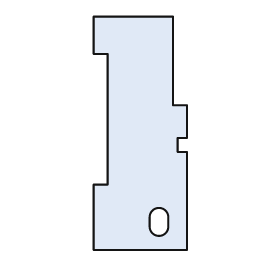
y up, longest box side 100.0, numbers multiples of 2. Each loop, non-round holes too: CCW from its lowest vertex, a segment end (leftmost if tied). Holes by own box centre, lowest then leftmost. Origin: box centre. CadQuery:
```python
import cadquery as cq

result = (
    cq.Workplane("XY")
    .moveTo(-20.0, -50.0)
    .lineTo(20.0, -50.0)
    .lineTo(20.0, -8.0)
    .lineTo(16.0, -8.0)
    .lineTo(16.0, -2.0)
    .lineTo(20.0, -2.0)
    .lineTo(20.0, 12.0)
    .lineTo(14.0, 12.0)
    .lineTo(14.0, 50.0)
    .lineTo(-20.0, 50.0)
    .lineTo(-20.0, 34.0)
    .lineTo(-14.0, 34.0)
    .lineTo(-14.0, -22.0)
    .lineTo(-20.0, -22.0)
    .close()
    .moveTo(4.0, -40.0)
    .threePointArc((8.0, -44.0), (12.0, -40.0))
    .lineTo(12.0, -36.0)
    .threePointArc((8.0, -32.0), (4.0, -36.0))
    .close()
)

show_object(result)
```